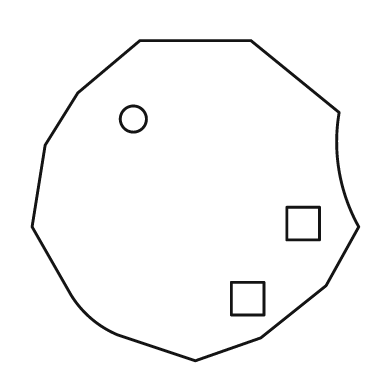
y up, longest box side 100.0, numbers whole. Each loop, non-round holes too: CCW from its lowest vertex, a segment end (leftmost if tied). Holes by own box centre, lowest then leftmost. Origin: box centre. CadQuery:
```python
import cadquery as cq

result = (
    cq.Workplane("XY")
    .moveTo(0.0, -49.0)
    .lineTo(20.0, -42.0)
    .lineTo(40.0, -26.0)
    .lineTo(50.0, -8.0)
    .threePointArc((44.0, 9.0), (44.0, 27.0))
    .lineTo(17.0, 49.0)
    .lineTo(-17.0, 49.0)
    .lineTo(-36.0, 33.0)
    .lineTo(-46.0, 17.0)
    .lineTo(-50.0, -8.0)
    .lineTo(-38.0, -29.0)
    .threePointArc((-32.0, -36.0), (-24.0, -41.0))
    .close()
    .moveTo(11.0, -35.0)
    .lineTo(21.0, -35.0)
    .lineTo(21.0, -25.0)
    .lineTo(11.0, -25.0)
    .close()
    .moveTo(28.0, -12.0)
    .lineTo(38.0, -12.0)
    .lineTo(38.0, -2.0)
    .lineTo(28.0, -2.0)
    .close()
    .moveTo(-19.0, 25.0)
    .circle(4.0)
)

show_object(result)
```